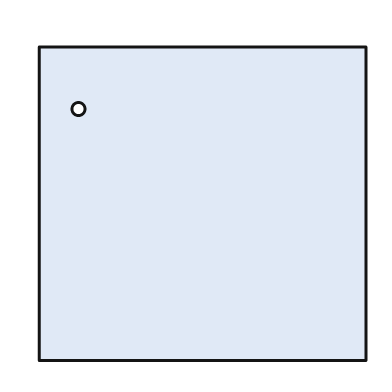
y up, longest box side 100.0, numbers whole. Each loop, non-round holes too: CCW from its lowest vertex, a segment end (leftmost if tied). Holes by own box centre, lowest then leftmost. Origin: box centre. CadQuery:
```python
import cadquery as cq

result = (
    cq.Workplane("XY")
    .moveTo(-50.0, -48.0)
    .lineTo(50.0, -48.0)
    .lineTo(50.0, 48.0)
    .lineTo(-50.0, 48.0)
    .close()
    .moveTo(-38.0, 29.0)
    .circle(2.0)
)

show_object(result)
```